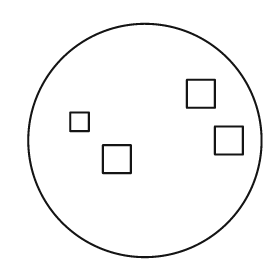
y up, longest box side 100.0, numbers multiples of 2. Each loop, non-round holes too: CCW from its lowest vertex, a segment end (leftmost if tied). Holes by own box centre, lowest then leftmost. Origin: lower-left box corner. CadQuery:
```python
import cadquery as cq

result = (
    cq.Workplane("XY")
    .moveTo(50.0, 50.0)
    .circle(50.0)
    .moveTo(32.0, 36.0)
    .lineTo(44.0, 36.0)
    .lineTo(44.0, 48.0)
    .lineTo(32.0, 48.0)
    .close()
    .moveTo(80.0, 44.0)
    .lineTo(92.0, 44.0)
    .lineTo(92.0, 56.0)
    .lineTo(80.0, 56.0)
    .close()
    .moveTo(18.0, 54.0)
    .lineTo(26.0, 54.0)
    .lineTo(26.0, 62.0)
    .lineTo(18.0, 62.0)
    .close()
    .moveTo(68.0, 64.0)
    .lineTo(80.0, 64.0)
    .lineTo(80.0, 76.0)
    .lineTo(68.0, 76.0)
    .close()
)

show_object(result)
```